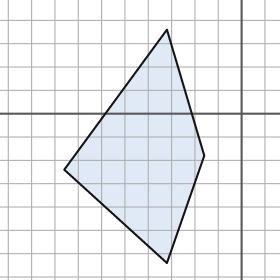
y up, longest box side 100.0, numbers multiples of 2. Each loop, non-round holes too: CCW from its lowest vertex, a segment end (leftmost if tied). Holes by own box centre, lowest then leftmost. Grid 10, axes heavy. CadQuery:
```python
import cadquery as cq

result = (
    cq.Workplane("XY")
    .moveTo(-32.0, -64.0)
    .lineTo(-16.0, -18.0)
    .lineTo(-32.0, 36.0)
    .lineTo(-76.0, -24.0)
    .close()
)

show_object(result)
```